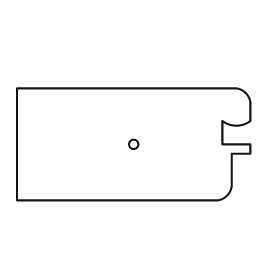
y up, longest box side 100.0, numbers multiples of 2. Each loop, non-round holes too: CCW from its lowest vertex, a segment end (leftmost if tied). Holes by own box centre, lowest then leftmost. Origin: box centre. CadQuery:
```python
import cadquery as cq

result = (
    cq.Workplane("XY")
    .moveTo(-50.0, -24.0)
    .lineTo(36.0, -24.0)
    .threePointArc((40.0, -22.0), (42.0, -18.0))
    .lineTo(42.0, -4.0)
    .lineTo(50.0, -4.0)
    .lineTo(50.0, 0.0)
    .lineTo(38.0, 0.0)
    .lineTo(38.0, 10.0)
    .threePointArc((44.0, 8.0), (50.0, 10.0))
    .lineTo(50.0, 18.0)
    .threePointArc((48.0, 22.0), (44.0, 24.0))
    .lineTo(-50.0, 24.0)
    .close()
    .moveTo(0.0, 0.0)
    .circle(2.0)
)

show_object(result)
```